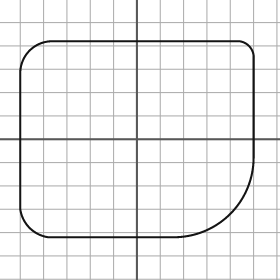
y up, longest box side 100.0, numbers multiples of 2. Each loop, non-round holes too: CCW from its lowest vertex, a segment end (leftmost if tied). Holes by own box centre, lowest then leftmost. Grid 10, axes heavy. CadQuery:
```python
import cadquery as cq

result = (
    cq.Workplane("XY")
    .moveTo(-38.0, -42.0)
    .lineTo(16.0, -42.0)
    .threePointArc((40.0, -32.0), (50.0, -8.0))
    .lineTo(50.0, 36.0)
    .threePointArc((48.0, 40.0), (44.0, 42.0))
    .lineTo(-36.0, 42.0)
    .threePointArc((-46.0, 38.0), (-50.0, 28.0))
    .lineTo(-50.0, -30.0)
    .threePointArc((-46.0, -38.0), (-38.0, -42.0))
    .close()
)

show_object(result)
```